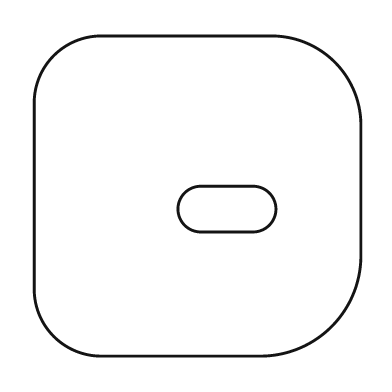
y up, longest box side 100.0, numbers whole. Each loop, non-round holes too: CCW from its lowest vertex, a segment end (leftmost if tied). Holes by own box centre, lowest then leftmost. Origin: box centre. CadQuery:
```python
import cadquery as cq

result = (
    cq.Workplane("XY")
    .moveTo(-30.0, -49.0)
    .lineTo(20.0, -49.0)
    .threePointArc((41.0, -40.0), (50.0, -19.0))
    .lineTo(50.0, 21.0)
    .threePointArc((42.0, 41.0), (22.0, 49.0))
    .lineTo(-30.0, 49.0)
    .threePointArc((-44.0, 43.0), (-50.0, 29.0))
    .lineTo(-50.0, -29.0)
    .threePointArc((-44.0, -43.0), (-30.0, -49.0))
    .close()
    .moveTo(1.0, -11.0)
    .lineTo(17.0, -11.0)
    .threePointArc((24.0, -4.0), (17.0, 3.0))
    .lineTo(1.0, 3.0)
    .threePointArc((-6.0, -4.0), (1.0, -11.0))
    .close()
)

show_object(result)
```